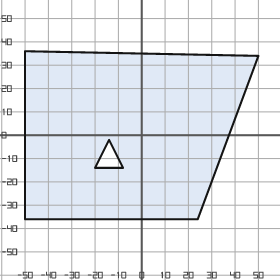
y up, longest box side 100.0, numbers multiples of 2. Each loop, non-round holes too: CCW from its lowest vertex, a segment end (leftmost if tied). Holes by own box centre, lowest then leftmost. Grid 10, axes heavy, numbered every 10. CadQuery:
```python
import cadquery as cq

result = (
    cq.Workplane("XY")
    .moveTo(-50.0, -36.0)
    .lineTo(24.0, -36.0)
    .lineTo(50.0, 34.0)
    .lineTo(-50.0, 36.0)
    .close()
    .moveTo(-20.0, -14.0)
    .lineTo(-8.0, -14.0)
    .lineTo(-14.0, -2.0)
    .close()
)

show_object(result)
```